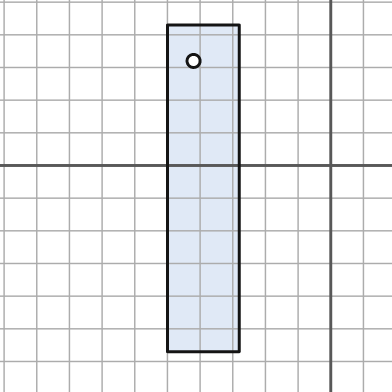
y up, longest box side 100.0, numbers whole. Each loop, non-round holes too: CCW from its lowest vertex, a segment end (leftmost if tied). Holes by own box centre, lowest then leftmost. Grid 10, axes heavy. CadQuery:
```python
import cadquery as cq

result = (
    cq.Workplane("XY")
    .moveTo(-50.0, -57.0)
    .lineTo(-28.0, -57.0)
    .lineTo(-28.0, 43.0)
    .lineTo(-50.0, 43.0)
    .close()
    .moveTo(-42.0, 32.0)
    .circle(2.0)
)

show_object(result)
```